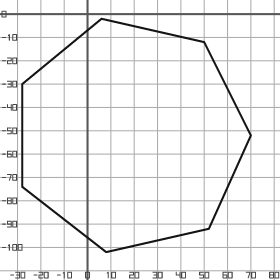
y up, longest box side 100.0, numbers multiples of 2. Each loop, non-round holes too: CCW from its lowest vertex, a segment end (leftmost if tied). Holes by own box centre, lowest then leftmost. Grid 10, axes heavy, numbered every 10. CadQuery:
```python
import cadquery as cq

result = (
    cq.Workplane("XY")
    .moveTo(8.0, -102.0)
    .lineTo(52.0, -92.0)
    .lineTo(70.0, -52.0)
    .lineTo(50.0, -12.0)
    .lineTo(6.0, -2.0)
    .lineTo(-28.0, -30.0)
    .lineTo(-28.0, -74.0)
    .close()
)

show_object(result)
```